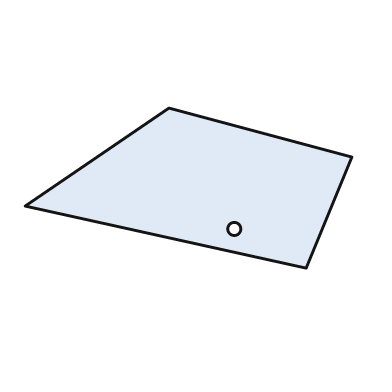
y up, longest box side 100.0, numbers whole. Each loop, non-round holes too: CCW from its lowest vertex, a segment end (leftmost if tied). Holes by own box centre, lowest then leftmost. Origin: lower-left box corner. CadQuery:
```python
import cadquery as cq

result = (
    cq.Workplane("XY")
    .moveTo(86.0, 0.0)
    .lineTo(100.0, 34.0)
    .lineTo(44.0, 49.0)
    .lineTo(0.0, 19.0)
    .close()
    .moveTo(64.0, 12.0)
    .circle(2.0)
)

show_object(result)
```